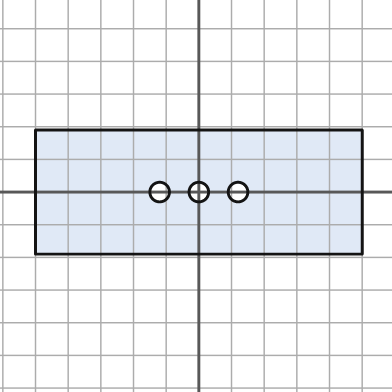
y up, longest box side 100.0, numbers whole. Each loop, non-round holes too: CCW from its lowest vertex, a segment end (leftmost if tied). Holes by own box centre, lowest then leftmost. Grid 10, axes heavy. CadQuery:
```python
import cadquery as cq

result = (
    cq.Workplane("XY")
    .moveTo(-50.0, -19.0)
    .lineTo(50.0, -19.0)
    .lineTo(50.0, 19.0)
    .lineTo(-50.0, 19.0)
    .close()
    .moveTo(-12.0, 0.0)
    .circle(3.0)
    .moveTo(0.0, 0.0)
    .circle(3.0)
    .moveTo(12.0, 0.0)
    .circle(3.0)
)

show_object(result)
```